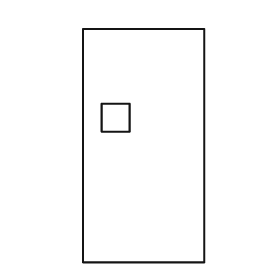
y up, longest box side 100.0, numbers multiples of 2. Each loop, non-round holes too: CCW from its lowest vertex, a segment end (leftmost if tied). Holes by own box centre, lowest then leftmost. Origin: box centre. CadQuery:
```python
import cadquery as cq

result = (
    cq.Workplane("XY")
    .moveTo(-26.0, -50.0)
    .lineTo(26.0, -50.0)
    .lineTo(26.0, 50.0)
    .lineTo(-26.0, 50.0)
    .close()
    .moveTo(-18.0, 6.0)
    .lineTo(-6.0, 6.0)
    .lineTo(-6.0, 18.0)
    .lineTo(-18.0, 18.0)
    .close()
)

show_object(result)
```